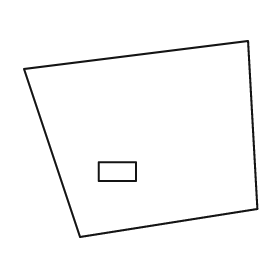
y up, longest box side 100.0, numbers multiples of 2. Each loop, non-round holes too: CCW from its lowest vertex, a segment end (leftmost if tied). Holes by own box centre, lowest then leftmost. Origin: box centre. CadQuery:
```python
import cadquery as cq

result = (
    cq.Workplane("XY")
    .moveTo(-26.0, -42.0)
    .lineTo(50.0, -30.0)
    .lineTo(46.0, 42.0)
    .lineTo(-50.0, 30.0)
    .close()
    .moveTo(-18.0, -18.0)
    .lineTo(-2.0, -18.0)
    .lineTo(-2.0, -10.0)
    .lineTo(-18.0, -10.0)
    .close()
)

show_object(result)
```